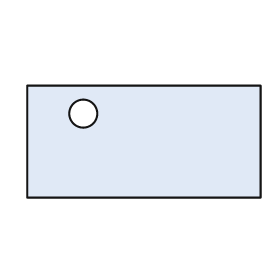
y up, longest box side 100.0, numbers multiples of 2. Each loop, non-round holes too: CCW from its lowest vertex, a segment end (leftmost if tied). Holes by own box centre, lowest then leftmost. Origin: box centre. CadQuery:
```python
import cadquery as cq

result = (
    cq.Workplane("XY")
    .moveTo(-50.0, -24.0)
    .lineTo(50.0, -24.0)
    .lineTo(50.0, 24.0)
    .lineTo(-50.0, 24.0)
    .close()
    .moveTo(-26.0, 12.0)
    .circle(6.0)
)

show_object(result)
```